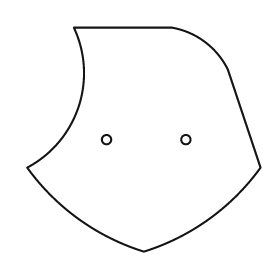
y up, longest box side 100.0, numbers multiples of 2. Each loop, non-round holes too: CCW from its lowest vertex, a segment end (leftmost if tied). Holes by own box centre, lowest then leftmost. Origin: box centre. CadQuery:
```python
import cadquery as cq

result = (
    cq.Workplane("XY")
    .moveTo(0.0, -48.0)
    .threePointArc((28.0, -34.0), (50.0, -12.0))
    .lineTo(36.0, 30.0)
    .threePointArc((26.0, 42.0), (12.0, 48.0))
    .lineTo(-30.0, 48.0)
    .threePointArc((-28.0, 14.0), (-50.0, -12.0))
    .threePointArc((-28.0, -34.0), (0.0, -48.0))
    .close()
    .moveTo(-16.0, 0.0)
    .circle(2.0)
    .moveTo(18.0, 0.0)
    .circle(2.0)
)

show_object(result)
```